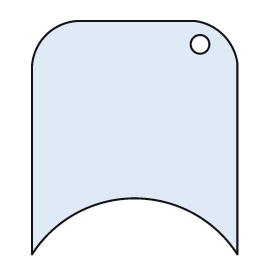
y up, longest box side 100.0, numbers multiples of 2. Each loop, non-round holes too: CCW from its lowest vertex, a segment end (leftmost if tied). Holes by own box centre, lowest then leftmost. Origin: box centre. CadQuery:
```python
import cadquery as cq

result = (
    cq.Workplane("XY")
    .moveTo(-44.0, -50.0)
    .threePointArc((0.0, -26.0), (44.0, -50.0))
    .lineTo(44.0, 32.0)
    .threePointArc((38.0, 44.0), (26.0, 50.0))
    .lineTo(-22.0, 50.0)
    .threePointArc((-38.0, 44.0), (-44.0, 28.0))
    .close()
    .moveTo(28.0, 40.0)
    .circle(4.0)
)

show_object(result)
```